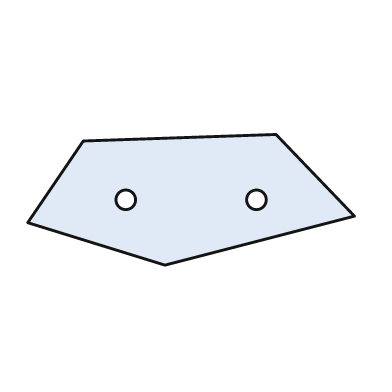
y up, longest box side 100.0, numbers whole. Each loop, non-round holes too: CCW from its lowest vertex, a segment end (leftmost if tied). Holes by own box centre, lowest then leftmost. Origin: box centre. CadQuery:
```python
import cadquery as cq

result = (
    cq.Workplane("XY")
    .moveTo(-8.0, -20.0)
    .lineTo(50.0, -5.0)
    .lineTo(26.0, 20.0)
    .lineTo(-33.0, 18.0)
    .lineTo(-50.0, -7.0)
    .close()
    .moveTo(-20.0, 0.0)
    .circle(3.0)
    .moveTo(20.0, 0.0)
    .circle(3.0)
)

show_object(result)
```